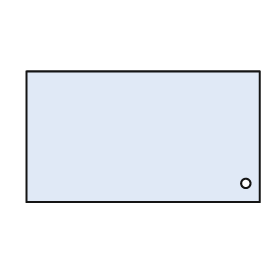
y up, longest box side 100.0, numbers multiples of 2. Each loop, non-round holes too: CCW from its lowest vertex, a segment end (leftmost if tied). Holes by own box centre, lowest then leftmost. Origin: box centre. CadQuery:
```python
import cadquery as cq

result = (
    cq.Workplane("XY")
    .moveTo(-50.0, -28.0)
    .lineTo(50.0, -28.0)
    .lineTo(50.0, 28.0)
    .lineTo(-50.0, 28.0)
    .close()
    .moveTo(44.0, -20.0)
    .circle(2.0)
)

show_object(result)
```